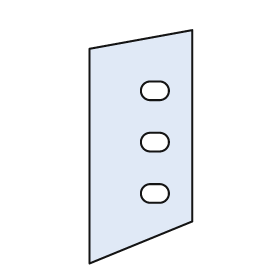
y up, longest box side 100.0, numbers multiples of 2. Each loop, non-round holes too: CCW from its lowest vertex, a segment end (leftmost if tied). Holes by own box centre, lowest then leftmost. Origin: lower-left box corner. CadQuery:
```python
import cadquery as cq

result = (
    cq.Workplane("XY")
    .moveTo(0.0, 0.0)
    .lineTo(44.0, 18.0)
    .lineTo(44.0, 100.0)
    .lineTo(0.0, 92.0)
    .close()
    .moveTo(26.0, 26.0)
    .lineTo(30.0, 26.0)
    .threePointArc((34.0, 30.0), (30.0, 34.0))
    .lineTo(26.0, 34.0)
    .threePointArc((22.0, 30.0), (26.0, 26.0))
    .close()
    .moveTo(26.0, 48.0)
    .lineTo(30.0, 48.0)
    .threePointArc((34.0, 52.0), (30.0, 56.0))
    .lineTo(26.0, 56.0)
    .threePointArc((22.0, 52.0), (26.0, 48.0))
    .close()
    .moveTo(26.0, 70.0)
    .lineTo(30.0, 70.0)
    .threePointArc((34.0, 74.0), (30.0, 78.0))
    .lineTo(26.0, 78.0)
    .threePointArc((22.0, 74.0), (26.0, 70.0))
    .close()
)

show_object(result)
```